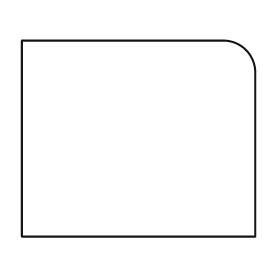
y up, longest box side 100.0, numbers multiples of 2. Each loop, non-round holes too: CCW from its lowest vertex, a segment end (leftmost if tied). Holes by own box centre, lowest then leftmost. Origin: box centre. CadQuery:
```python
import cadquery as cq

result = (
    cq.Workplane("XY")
    .moveTo(-50.0, -42.0)
    .lineTo(50.0, -42.0)
    .lineTo(50.0, 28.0)
    .threePointArc((46.0, 38.0), (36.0, 42.0))
    .lineTo(-50.0, 42.0)
    .close()
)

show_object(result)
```